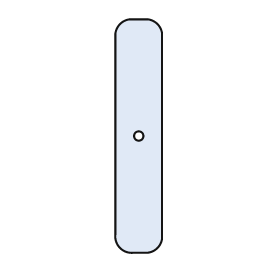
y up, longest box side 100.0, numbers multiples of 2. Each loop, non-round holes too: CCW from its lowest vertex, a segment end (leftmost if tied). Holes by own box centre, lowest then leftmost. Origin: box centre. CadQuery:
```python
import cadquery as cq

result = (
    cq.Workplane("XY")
    .moveTo(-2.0, -50.0)
    .lineTo(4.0, -50.0)
    .threePointArc((8.0, -48.0), (10.0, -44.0))
    .lineTo(10.0, 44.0)
    .threePointArc((8.0, 48.0), (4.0, 50.0))
    .lineTo(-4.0, 50.0)
    .threePointArc((-8.0, 48.0), (-10.0, 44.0))
    .lineTo(-10.0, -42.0)
    .threePointArc((-8.0, -48.0), (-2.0, -50.0))
    .close()
    .moveTo(0.0, 0.0)
    .circle(2.0)
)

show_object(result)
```